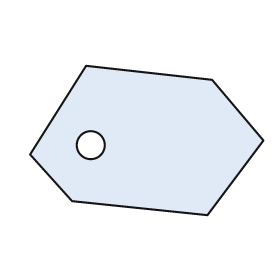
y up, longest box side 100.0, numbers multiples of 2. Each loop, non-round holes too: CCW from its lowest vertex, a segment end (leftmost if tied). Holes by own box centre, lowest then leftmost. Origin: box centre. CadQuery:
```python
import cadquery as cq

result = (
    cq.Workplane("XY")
    .moveTo(26.0, -32.0)
    .lineTo(50.0, 0.0)
    .lineTo(28.0, 26.0)
    .lineTo(-26.0, 32.0)
    .lineTo(-50.0, -6.0)
    .lineTo(-32.0, -26.0)
    .close()
    .moveTo(-24.0, -2.0)
    .circle(6.0)
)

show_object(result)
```